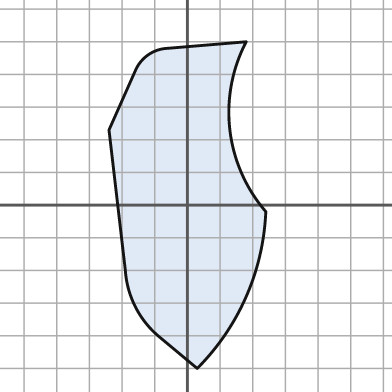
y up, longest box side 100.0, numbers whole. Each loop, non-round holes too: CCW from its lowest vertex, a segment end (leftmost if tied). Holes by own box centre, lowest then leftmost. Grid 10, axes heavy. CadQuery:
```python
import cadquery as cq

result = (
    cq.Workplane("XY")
    .moveTo(3.0, -50.0)
    .threePointArc((18.0, -28.0), (24.0, -2.0))
    .threePointArc((13.0, 23.0), (18.0, 50.0))
    .lineTo(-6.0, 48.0)
    .threePointArc((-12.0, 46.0), (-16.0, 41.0))
    .lineTo(-24.0, 23.0)
    .lineTo(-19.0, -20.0)
    .threePointArc((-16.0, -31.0), (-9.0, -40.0))
    .close()
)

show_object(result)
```